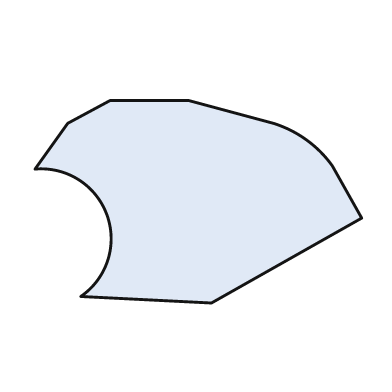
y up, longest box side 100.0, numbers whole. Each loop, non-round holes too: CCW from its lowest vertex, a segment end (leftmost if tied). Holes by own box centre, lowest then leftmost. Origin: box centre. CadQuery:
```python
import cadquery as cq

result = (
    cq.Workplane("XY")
    .moveTo(4.0, -31.0)
    .lineTo(50.0, -5.0)
    .lineTo(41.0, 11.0)
    .threePointArc((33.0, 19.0), (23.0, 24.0))
    .lineTo(-3.0, 31.0)
    .lineTo(-27.0, 31.0)
    .lineTo(-40.0, 24.0)
    .lineTo(-50.0, 10.0)
    .threePointArc((-28.0, -4.0), (-36.0, -29.0))
    .close()
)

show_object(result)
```